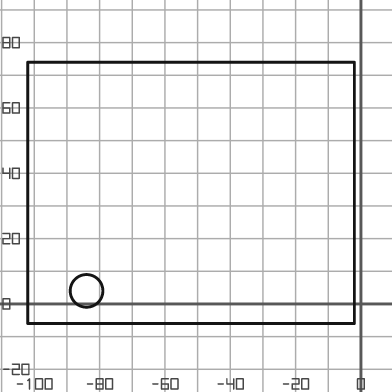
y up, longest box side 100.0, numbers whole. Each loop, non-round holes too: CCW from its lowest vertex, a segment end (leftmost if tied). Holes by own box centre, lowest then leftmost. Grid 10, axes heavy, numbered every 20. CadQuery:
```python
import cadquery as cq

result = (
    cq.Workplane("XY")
    .moveTo(-102.0, -6.0)
    .lineTo(-2.0, -6.0)
    .lineTo(-2.0, 74.0)
    .lineTo(-102.0, 74.0)
    .close()
    .moveTo(-84.0, 4.0)
    .circle(5.0)
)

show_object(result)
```